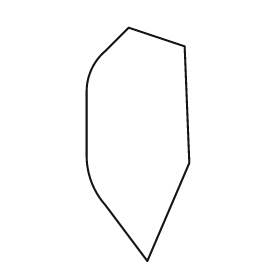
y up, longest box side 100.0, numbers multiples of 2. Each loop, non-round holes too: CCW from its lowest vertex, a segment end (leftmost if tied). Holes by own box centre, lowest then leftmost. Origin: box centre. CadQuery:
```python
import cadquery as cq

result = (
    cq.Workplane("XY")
    .moveTo(4.0, -50.0)
    .lineTo(22.0, -8.0)
    .lineTo(20.0, 42.0)
    .lineTo(-4.0, 50.0)
    .lineTo(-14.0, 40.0)
    .threePointArc((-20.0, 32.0), (-22.0, 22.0))
    .lineTo(-22.0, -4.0)
    .threePointArc((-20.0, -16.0), (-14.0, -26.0))
    .close()
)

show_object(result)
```